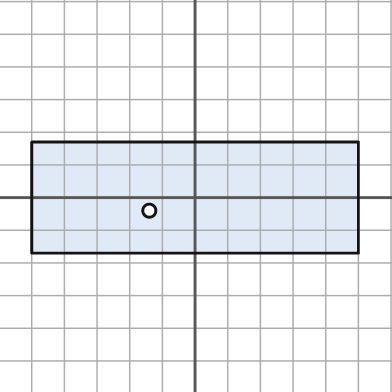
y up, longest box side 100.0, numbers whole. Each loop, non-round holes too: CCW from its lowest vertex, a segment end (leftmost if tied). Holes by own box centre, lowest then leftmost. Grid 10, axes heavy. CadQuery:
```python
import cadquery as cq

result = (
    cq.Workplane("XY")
    .moveTo(-50.0, -17.0)
    .lineTo(50.0, -17.0)
    .lineTo(50.0, 17.0)
    .lineTo(-50.0, 17.0)
    .close()
    .moveTo(-14.0, -4.0)
    .circle(2.0)
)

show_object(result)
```